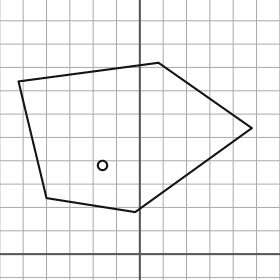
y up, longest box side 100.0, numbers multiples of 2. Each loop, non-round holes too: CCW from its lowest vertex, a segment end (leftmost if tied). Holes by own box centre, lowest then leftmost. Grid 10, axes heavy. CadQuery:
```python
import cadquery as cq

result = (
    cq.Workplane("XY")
    .moveTo(-2.0, 18.0)
    .lineTo(48.0, 54.0)
    .lineTo(8.0, 82.0)
    .lineTo(-52.0, 74.0)
    .lineTo(-40.0, 24.0)
    .close()
    .moveTo(-16.0, 38.0)
    .circle(2.0)
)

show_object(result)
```